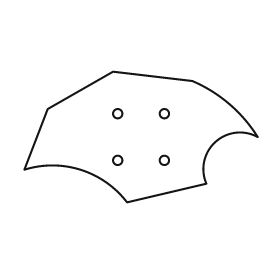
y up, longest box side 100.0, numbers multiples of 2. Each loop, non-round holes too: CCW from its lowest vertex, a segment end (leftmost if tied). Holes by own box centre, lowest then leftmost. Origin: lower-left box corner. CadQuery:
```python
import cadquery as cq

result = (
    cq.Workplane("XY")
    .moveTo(44.0, 0.0)
    .lineTo(78.0, 8.0)
    .threePointArc((82.0, 26.0), (100.0, 28.0))
    .threePointArc((88.0, 42.0), (72.0, 52.0))
    .lineTo(38.0, 56.0)
    .lineTo(10.0, 40.0)
    .lineTo(0.0, 14.0)
    .threePointArc((24.0, 14.0), (44.0, 0.0))
    .close()
    .moveTo(40.0, 18.0)
    .circle(2.0)
    .moveTo(60.0, 18.0)
    .circle(2.0)
    .moveTo(40.0, 38.0)
    .circle(2.0)
    .moveTo(60.0, 38.0)
    .circle(2.0)
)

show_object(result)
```